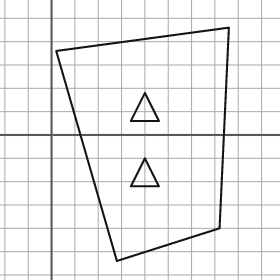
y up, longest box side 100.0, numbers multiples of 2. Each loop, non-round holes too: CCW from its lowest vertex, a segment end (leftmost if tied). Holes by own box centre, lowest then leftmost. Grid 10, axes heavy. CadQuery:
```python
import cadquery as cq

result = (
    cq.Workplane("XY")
    .moveTo(28.0, -54.0)
    .lineTo(72.0, -40.0)
    .lineTo(76.0, 46.0)
    .lineTo(2.0, 36.0)
    .close()
    .moveTo(34.0, -22.0)
    .lineTo(46.0, -22.0)
    .lineTo(40.0, -10.0)
    .close()
    .moveTo(34.0, 6.0)
    .lineTo(46.0, 6.0)
    .lineTo(40.0, 18.0)
    .close()
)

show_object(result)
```